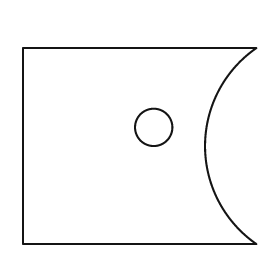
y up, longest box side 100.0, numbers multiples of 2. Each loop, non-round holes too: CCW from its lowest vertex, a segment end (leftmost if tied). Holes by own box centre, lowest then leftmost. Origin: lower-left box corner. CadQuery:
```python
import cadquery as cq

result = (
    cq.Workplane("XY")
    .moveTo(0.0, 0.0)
    .lineTo(100.0, 0.0)
    .threePointArc((78.0, 42.0), (100.0, 84.0))
    .lineTo(0.0, 84.0)
    .close()
    .moveTo(56.0, 50.0)
    .circle(8.0)
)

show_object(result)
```